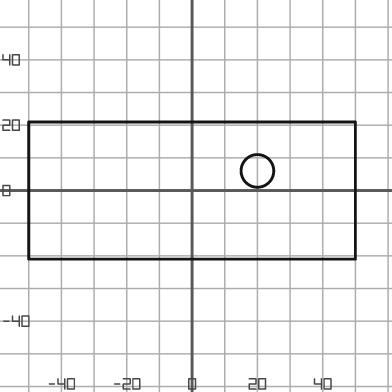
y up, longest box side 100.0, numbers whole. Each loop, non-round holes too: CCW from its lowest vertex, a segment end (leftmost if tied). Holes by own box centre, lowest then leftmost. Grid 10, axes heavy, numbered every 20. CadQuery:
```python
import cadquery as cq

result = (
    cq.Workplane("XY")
    .moveTo(-50.0, -21.0)
    .lineTo(50.0, -21.0)
    .lineTo(50.0, 21.0)
    .lineTo(-50.0, 21.0)
    .close()
    .moveTo(20.0, 6.0)
    .circle(5.0)
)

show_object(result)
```